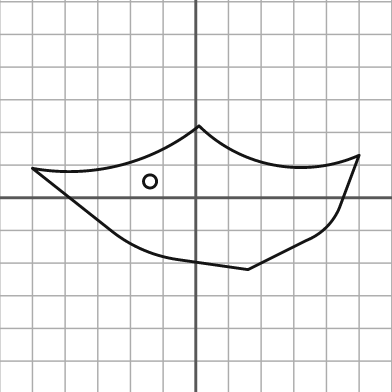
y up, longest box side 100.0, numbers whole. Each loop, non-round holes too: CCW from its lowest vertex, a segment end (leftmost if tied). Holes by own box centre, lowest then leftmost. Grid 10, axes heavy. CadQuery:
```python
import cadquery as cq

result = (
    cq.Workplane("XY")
    .moveTo(16.0, -22.0)
    .lineTo(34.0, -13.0)
    .threePointArc((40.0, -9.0), (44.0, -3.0))
    .lineTo(50.0, 13.0)
    .threePointArc((24.0, 10.0), (1.0, 22.0))
    .threePointArc((-23.0, 10.0), (-50.0, 9.0))
    .lineTo(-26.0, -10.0)
    .threePointArc((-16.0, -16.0), (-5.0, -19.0))
    .close()
    .moveTo(-14.0, 5.0)
    .circle(2.0)
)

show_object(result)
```